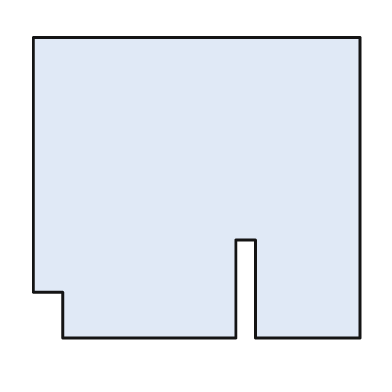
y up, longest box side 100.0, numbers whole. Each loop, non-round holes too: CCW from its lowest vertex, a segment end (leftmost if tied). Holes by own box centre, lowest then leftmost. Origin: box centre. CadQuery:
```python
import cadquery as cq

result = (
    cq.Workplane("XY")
    .moveTo(-41.0, -46.0)
    .lineTo(12.0, -46.0)
    .lineTo(12.0, -16.0)
    .lineTo(18.0, -16.0)
    .lineTo(18.0, -46.0)
    .lineTo(50.0, -46.0)
    .lineTo(50.0, 46.0)
    .lineTo(-50.0, 46.0)
    .lineTo(-50.0, -32.0)
    .lineTo(-41.0, -32.0)
    .close()
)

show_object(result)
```